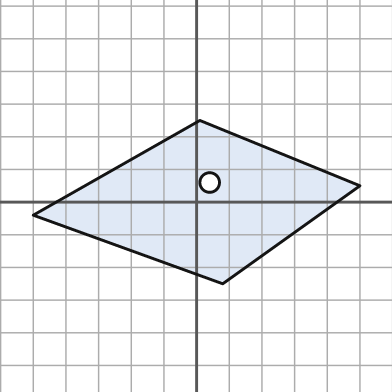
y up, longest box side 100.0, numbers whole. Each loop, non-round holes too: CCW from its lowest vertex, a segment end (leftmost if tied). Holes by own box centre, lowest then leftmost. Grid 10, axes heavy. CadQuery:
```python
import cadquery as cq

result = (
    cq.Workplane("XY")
    .moveTo(8.0, -25.0)
    .lineTo(50.0, 5.0)
    .lineTo(1.0, 25.0)
    .lineTo(-50.0, -4.0)
    .close()
    .moveTo(4.0, 6.0)
    .circle(3.0)
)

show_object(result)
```